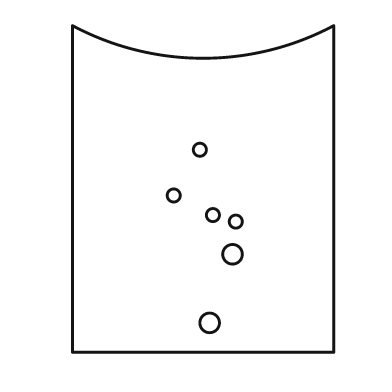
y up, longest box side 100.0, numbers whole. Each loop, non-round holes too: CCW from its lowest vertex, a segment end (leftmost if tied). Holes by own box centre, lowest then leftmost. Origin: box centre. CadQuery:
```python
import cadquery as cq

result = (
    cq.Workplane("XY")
    .moveTo(-40.0, -50.0)
    .lineTo(40.0, -50.0)
    .lineTo(40.0, 50.0)
    .threePointArc((0.0, 40.0), (-40.0, 50.0))
    .close()
    .moveTo(2.0, -41.0)
    .circle(3.0)
    .moveTo(9.0, -20.0)
    .circle(3.0)
    .moveTo(10.0, -10.0)
    .circle(2.0)
    .moveTo(3.0, -8.0)
    .circle(2.0)
    .moveTo(-9.0, -2.0)
    .circle(2.0)
    .moveTo(-1.0, 12.0)
    .circle(2.0)
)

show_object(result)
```